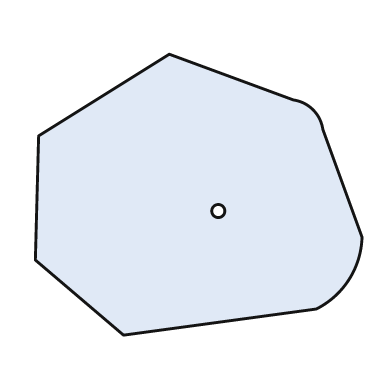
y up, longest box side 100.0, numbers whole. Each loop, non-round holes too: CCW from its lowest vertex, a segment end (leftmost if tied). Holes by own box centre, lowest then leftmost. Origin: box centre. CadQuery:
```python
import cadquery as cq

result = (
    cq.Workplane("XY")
    .moveTo(-23.0, -43.0)
    .lineTo(36.0, -35.0)
    .threePointArc((46.0, -26.0), (50.0, -13.0))
    .lineTo(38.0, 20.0)
    .threePointArc((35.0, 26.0), (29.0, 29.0))
    .lineTo(-9.0, 43.0)
    .lineTo(-49.0, 18.0)
    .lineTo(-50.0, -20.0)
    .close()
    .moveTo(6.0, -5.0)
    .circle(2.0)
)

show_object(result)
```